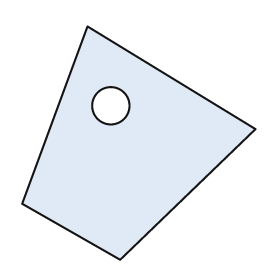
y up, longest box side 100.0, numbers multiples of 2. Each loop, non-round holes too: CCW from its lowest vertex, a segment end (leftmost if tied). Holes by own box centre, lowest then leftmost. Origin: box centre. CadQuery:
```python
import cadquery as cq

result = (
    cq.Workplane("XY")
    .moveTo(-8.0, -50.0)
    .lineTo(50.0, 6.0)
    .lineTo(-22.0, 50.0)
    .lineTo(-50.0, -26.0)
    .close()
    .moveTo(-12.0, 16.0)
    .circle(8.0)
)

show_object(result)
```